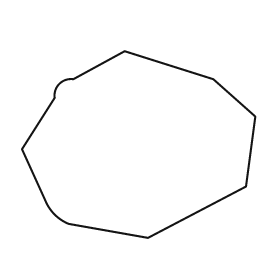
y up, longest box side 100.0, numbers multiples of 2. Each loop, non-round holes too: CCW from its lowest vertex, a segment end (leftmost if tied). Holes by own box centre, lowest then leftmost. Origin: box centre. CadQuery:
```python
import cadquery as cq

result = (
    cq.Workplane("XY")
    .moveTo(4.0, -40.0)
    .lineTo(46.0, -18.0)
    .lineTo(50.0, 12.0)
    .lineTo(32.0, 28.0)
    .lineTo(-6.0, 40.0)
    .lineTo(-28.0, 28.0)
    .threePointArc((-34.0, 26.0), (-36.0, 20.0))
    .lineTo(-50.0, -2.0)
    .lineTo(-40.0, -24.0)
    .threePointArc((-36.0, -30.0), (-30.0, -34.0))
    .close()
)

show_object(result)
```